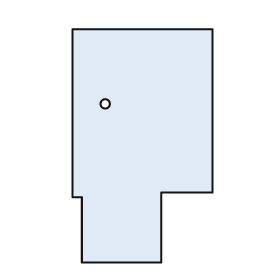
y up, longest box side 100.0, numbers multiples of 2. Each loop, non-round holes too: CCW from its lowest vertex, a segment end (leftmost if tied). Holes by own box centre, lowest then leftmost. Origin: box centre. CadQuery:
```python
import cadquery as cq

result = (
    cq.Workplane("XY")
    .moveTo(-26.0, -50.0)
    .lineTo(8.0, -50.0)
    .lineTo(8.0, -20.0)
    .lineTo(30.0, -20.0)
    .lineTo(30.0, 50.0)
    .lineTo(-30.0, 50.0)
    .lineTo(-30.0, -22.0)
    .lineTo(-26.0, -22.0)
    .close()
    .moveTo(-16.0, 18.0)
    .circle(2.0)
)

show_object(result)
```